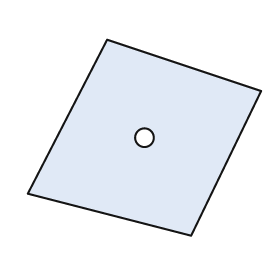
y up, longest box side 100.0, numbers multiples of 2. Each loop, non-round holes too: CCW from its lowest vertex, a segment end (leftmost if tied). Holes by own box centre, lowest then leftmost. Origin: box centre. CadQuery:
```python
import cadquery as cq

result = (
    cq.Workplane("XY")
    .moveTo(20.0, -42.0)
    .lineTo(50.0, 20.0)
    .lineTo(-16.0, 42.0)
    .lineTo(-50.0, -24.0)
    .close()
    .moveTo(0.0, 0.0)
    .circle(4.0)
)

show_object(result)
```